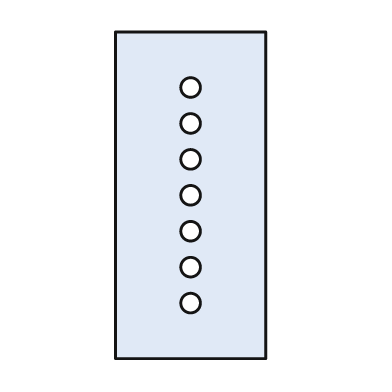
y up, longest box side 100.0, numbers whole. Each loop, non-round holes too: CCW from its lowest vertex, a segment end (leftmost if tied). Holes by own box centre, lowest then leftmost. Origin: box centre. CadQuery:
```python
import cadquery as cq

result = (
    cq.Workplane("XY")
    .moveTo(-23.0, -50.0)
    .lineTo(23.0, -50.0)
    .lineTo(23.0, 50.0)
    .lineTo(-23.0, 50.0)
    .close()
    .moveTo(0.0, -33.0)
    .circle(3.0)
    .moveTo(0.0, -22.0)
    .circle(3.0)
    .moveTo(0.0, -11.0)
    .circle(3.0)
    .moveTo(0.0, 0.0)
    .circle(3.0)
    .moveTo(0.0, 11.0)
    .circle(3.0)
    .moveTo(0.0, 22.0)
    .circle(3.0)
    .moveTo(0.0, 33.0)
    .circle(3.0)
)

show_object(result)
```